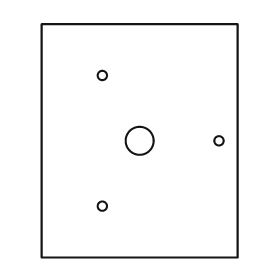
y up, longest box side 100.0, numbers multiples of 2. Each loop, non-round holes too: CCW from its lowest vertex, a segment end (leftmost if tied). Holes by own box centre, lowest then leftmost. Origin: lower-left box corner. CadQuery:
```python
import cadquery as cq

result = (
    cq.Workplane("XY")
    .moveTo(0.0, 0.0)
    .lineTo(84.0, 0.0)
    .lineTo(84.0, 100.0)
    .lineTo(0.0, 100.0)
    .close()
    .moveTo(26.0, 22.0)
    .circle(2.0)
    .moveTo(42.0, 50.0)
    .circle(6.0)
    .moveTo(76.0, 50.0)
    .circle(2.0)
    .moveTo(26.0, 78.0)
    .circle(2.0)
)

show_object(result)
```